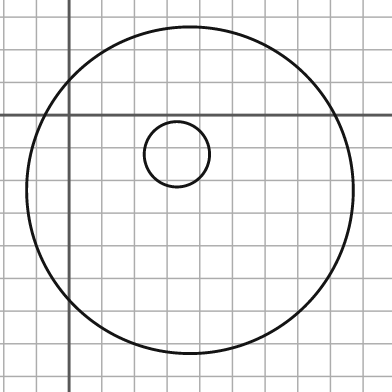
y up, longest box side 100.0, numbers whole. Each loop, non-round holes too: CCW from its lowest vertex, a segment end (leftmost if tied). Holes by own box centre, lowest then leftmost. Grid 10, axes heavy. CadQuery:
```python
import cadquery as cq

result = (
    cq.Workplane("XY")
    .moveTo(37.0, -23.0)
    .circle(50.0)
    .moveTo(33.0, -12.0)
    .circle(10.0)
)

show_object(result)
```